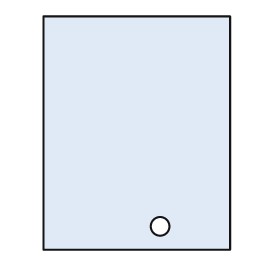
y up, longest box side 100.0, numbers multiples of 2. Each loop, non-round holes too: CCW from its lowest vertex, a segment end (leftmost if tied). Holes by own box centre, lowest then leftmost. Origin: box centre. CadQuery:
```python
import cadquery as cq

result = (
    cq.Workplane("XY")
    .moveTo(-40.0, -50.0)
    .lineTo(40.0, -50.0)
    .lineTo(40.0, 50.0)
    .lineTo(-40.0, 50.0)
    .close()
    .moveTo(10.0, -40.0)
    .circle(4.0)
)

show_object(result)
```